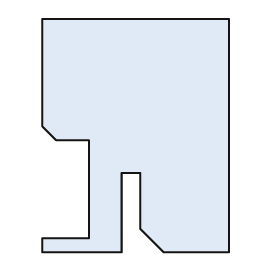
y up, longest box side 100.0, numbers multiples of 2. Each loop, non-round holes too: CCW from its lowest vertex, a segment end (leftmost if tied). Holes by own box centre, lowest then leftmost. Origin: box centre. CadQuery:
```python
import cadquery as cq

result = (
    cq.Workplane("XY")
    .moveTo(-40.0, -50.0)
    .lineTo(-6.0, -50.0)
    .lineTo(-6.0, -16.0)
    .lineTo(2.0, -16.0)
    .lineTo(2.0, -40.0)
    .lineTo(12.0, -50.0)
    .lineTo(40.0, -50.0)
    .lineTo(40.0, 50.0)
    .lineTo(-40.0, 50.0)
    .lineTo(-40.0, 4.0)
    .lineTo(-34.0, -2.0)
    .lineTo(-20.0, -2.0)
    .lineTo(-20.0, -44.0)
    .lineTo(-40.0, -44.0)
    .close()
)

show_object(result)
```